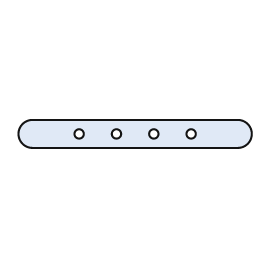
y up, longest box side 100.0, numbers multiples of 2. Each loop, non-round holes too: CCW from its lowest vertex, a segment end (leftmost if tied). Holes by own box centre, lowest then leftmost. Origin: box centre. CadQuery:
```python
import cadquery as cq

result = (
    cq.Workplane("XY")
    .moveTo(-44.0, -6.0)
    .lineTo(44.0, -6.0)
    .threePointArc((50.0, 0.0), (44.0, 6.0))
    .lineTo(-44.0, 6.0)
    .threePointArc((-50.0, 0.0), (-44.0, -6.0))
    .close()
    .moveTo(-24.0, 0.0)
    .circle(2.0)
    .moveTo(-8.0, 0.0)
    .circle(2.0)
    .moveTo(8.0, 0.0)
    .circle(2.0)
    .moveTo(24.0, 0.0)
    .circle(2.0)
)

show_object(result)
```